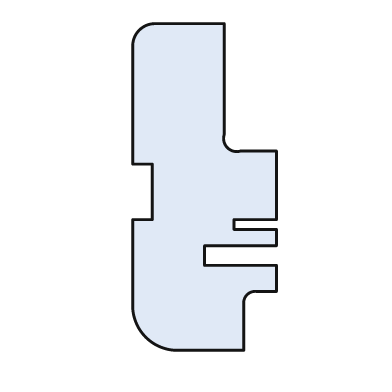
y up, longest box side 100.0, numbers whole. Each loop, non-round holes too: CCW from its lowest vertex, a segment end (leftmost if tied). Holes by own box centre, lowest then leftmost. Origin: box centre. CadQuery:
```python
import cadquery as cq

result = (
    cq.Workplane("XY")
    .moveTo(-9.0, -50.0)
    .lineTo(12.0, -50.0)
    .lineTo(12.0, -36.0)
    .threePointArc((13.0, -33.0), (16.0, -32.0))
    .lineTo(22.0, -32.0)
    .lineTo(22.0, -24.0)
    .lineTo(0.0, -24.0)
    .lineTo(0.0, -18.0)
    .lineTo(22.0, -18.0)
    .lineTo(22.0, -13.0)
    .lineTo(9.0, -13.0)
    .lineTo(9.0, -10.0)
    .lineTo(22.0, -10.0)
    .lineTo(22.0, 11.0)
    .lineTo(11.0, 11.0)
    .threePointArc((7.0, 12.0), (6.0, 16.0))
    .lineTo(6.0, 50.0)
    .lineTo(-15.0, 50.0)
    .threePointArc((-20.0, 48.0), (-22.0, 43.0))
    .lineTo(-22.0, 7.0)
    .lineTo(-16.0, 7.0)
    .lineTo(-16.0, -10.0)
    .lineTo(-22.0, -10.0)
    .lineTo(-22.0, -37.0)
    .threePointArc((-18.0, -46.0), (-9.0, -50.0))
    .close()
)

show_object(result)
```